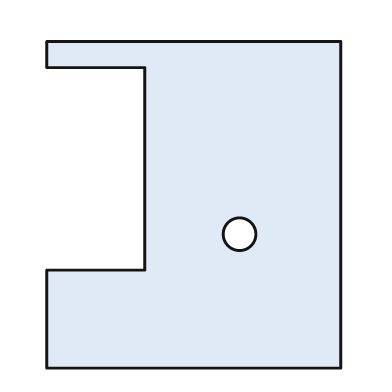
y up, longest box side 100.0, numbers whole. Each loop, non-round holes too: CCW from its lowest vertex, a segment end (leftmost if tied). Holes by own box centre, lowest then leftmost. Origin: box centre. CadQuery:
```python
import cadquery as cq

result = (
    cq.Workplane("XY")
    .moveTo(-45.0, -50.0)
    .lineTo(45.0, -50.0)
    .lineTo(45.0, 50.0)
    .lineTo(-45.0, 50.0)
    .lineTo(-45.0, 42.0)
    .lineTo(-15.0, 42.0)
    .lineTo(-15.0, -20.0)
    .lineTo(-45.0, -20.0)
    .close()
    .moveTo(14.0, -9.0)
    .circle(5.0)
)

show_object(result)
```